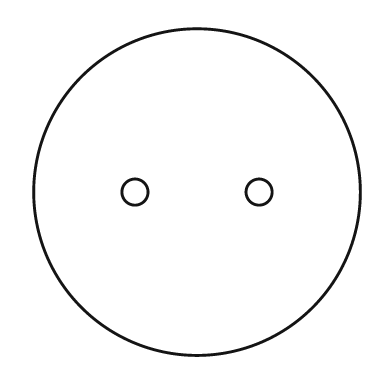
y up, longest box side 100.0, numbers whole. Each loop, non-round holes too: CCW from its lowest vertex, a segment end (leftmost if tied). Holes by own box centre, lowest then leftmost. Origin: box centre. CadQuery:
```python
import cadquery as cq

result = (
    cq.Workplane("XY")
    .moveTo(0.0, 0.0)
    .circle(50.0)
    .moveTo(-19.0, 0.0)
    .circle(4.0)
    .moveTo(19.0, 0.0)
    .circle(4.0)
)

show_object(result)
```